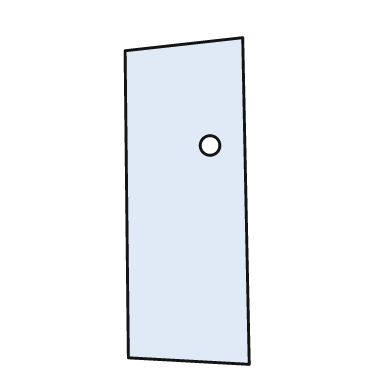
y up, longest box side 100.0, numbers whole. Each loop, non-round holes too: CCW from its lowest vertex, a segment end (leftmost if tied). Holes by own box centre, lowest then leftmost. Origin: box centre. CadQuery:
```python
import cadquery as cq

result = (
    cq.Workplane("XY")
    .moveTo(19.0, -50.0)
    .lineTo(17.0, 50.0)
    .lineTo(-19.0, 46.0)
    .lineTo(-18.0, -48.0)
    .close()
    .moveTo(7.0, 17.0)
    .circle(3.0)
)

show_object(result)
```